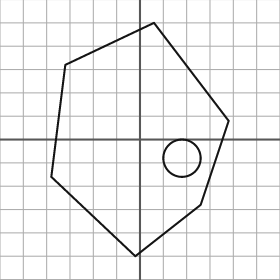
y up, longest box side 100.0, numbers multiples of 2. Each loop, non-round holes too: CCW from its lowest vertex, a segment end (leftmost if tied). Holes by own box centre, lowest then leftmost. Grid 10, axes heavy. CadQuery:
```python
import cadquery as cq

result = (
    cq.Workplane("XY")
    .moveTo(-2.0, -50.0)
    .lineTo(26.0, -28.0)
    .lineTo(38.0, 8.0)
    .lineTo(6.0, 50.0)
    .lineTo(-32.0, 32.0)
    .lineTo(-38.0, -16.0)
    .close()
    .moveTo(18.0, -8.0)
    .circle(8.0)
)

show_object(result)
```